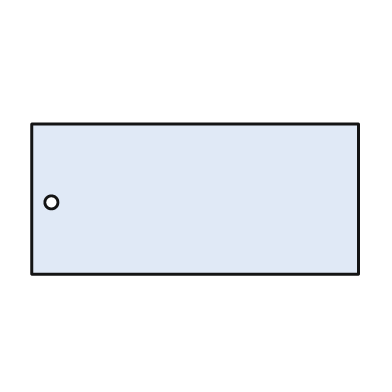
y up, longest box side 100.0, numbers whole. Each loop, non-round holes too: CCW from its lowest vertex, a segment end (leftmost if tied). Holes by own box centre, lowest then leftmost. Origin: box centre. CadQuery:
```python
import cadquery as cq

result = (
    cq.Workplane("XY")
    .moveTo(-50.0, -23.0)
    .lineTo(50.0, -23.0)
    .lineTo(50.0, 23.0)
    .lineTo(-50.0, 23.0)
    .close()
    .moveTo(-44.0, -1.0)
    .circle(2.0)
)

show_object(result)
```